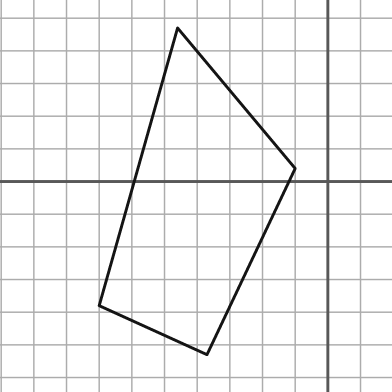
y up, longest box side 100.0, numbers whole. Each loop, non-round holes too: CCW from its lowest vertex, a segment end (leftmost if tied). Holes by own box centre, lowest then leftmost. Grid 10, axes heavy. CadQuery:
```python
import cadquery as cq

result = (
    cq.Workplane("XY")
    .moveTo(-37.0, -53.0)
    .lineTo(-10.0, 4.0)
    .lineTo(-46.0, 47.0)
    .lineTo(-70.0, -38.0)
    .close()
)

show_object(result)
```